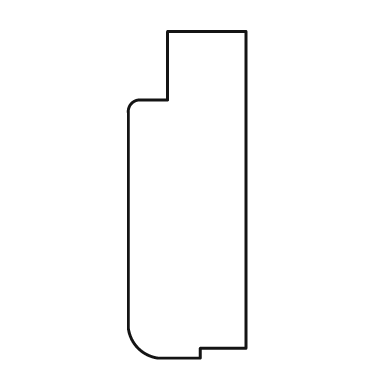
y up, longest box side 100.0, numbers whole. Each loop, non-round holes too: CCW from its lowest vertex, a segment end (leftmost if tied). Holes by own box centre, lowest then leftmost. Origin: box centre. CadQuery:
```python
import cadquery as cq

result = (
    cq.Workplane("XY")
    .moveTo(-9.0, -50.0)
    .lineTo(4.0, -50.0)
    .lineTo(4.0, -47.0)
    .lineTo(18.0, -47.0)
    .lineTo(18.0, 50.0)
    .lineTo(-6.0, 50.0)
    .lineTo(-6.0, 29.0)
    .lineTo(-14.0, 29.0)
    .threePointArc((-17.0, 28.0), (-18.0, 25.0))
    .lineTo(-18.0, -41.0)
    .threePointArc((-15.0, -47.0), (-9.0, -50.0))
    .close()
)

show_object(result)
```